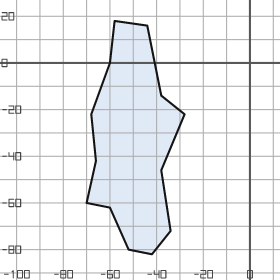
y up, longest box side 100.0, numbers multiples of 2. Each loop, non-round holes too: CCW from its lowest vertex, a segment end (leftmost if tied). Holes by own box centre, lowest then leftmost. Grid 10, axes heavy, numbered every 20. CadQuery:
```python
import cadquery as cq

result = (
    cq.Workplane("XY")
    .moveTo(-42.0, -82.0)
    .lineTo(-34.0, -72.0)
    .lineTo(-38.0, -46.0)
    .lineTo(-28.0, -22.0)
    .lineTo(-38.0, -14.0)
    .lineTo(-44.0, 16.0)
    .lineTo(-58.0, 18.0)
    .lineTo(-60.0, 0.0)
    .lineTo(-68.0, -22.0)
    .lineTo(-66.0, -42.0)
    .lineTo(-70.0, -60.0)
    .lineTo(-60.0, -62.0)
    .lineTo(-52.0, -80.0)
    .close()
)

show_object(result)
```